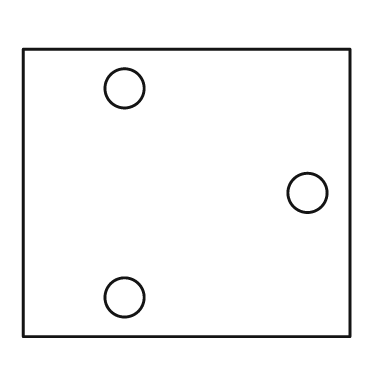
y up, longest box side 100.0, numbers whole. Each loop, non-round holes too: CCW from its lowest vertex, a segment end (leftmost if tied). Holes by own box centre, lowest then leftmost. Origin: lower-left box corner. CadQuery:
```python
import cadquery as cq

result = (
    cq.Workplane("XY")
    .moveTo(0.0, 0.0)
    .lineTo(100.0, 0.0)
    .lineTo(100.0, 88.0)
    .lineTo(0.0, 88.0)
    .close()
    .moveTo(31.0, 12.0)
    .circle(6.0)
    .moveTo(87.0, 44.0)
    .circle(6.0)
    .moveTo(31.0, 76.0)
    .circle(6.0)
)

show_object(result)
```